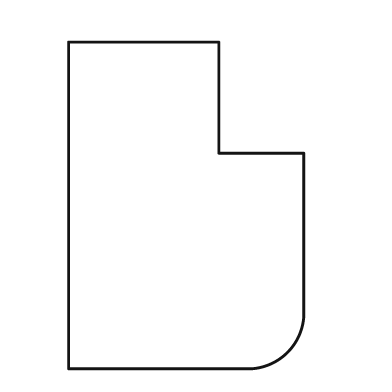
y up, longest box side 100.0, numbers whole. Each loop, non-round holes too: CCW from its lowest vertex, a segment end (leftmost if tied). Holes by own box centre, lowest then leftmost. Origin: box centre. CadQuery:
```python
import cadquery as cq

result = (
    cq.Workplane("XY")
    .moveTo(-36.0, -50.0)
    .lineTo(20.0, -50.0)
    .threePointArc((31.0, -45.0), (36.0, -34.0))
    .lineTo(36.0, 16.0)
    .lineTo(10.0, 16.0)
    .lineTo(10.0, 50.0)
    .lineTo(-36.0, 50.0)
    .close()
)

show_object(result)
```